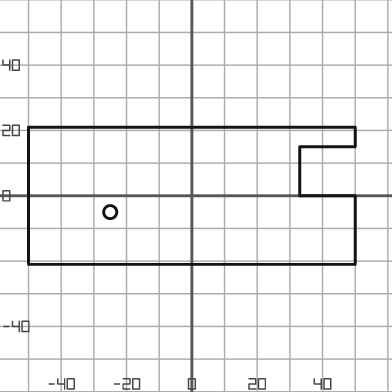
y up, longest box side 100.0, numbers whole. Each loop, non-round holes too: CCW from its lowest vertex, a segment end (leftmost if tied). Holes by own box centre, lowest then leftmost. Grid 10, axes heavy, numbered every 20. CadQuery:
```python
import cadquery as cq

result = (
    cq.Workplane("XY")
    .moveTo(-50.0, -21.0)
    .lineTo(50.0, -21.0)
    .lineTo(50.0, 0.0)
    .lineTo(33.0, 0.0)
    .lineTo(33.0, 15.0)
    .lineTo(50.0, 15.0)
    .lineTo(50.0, 21.0)
    .lineTo(-50.0, 21.0)
    .close()
    .moveTo(-25.0, -5.0)
    .circle(2.0)
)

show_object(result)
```